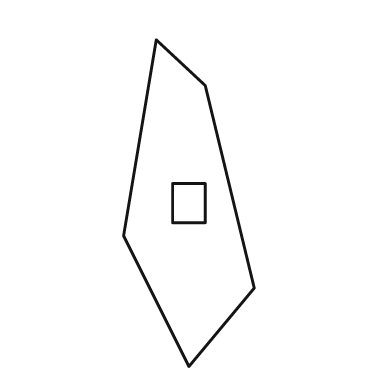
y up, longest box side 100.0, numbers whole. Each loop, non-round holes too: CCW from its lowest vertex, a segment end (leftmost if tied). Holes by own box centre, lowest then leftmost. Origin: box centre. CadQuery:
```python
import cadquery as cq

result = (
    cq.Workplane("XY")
    .moveTo(0.0, -50.0)
    .lineTo(20.0, -26.0)
    .lineTo(5.0, 36.0)
    .lineTo(-10.0, 50.0)
    .lineTo(-20.0, -10.0)
    .close()
    .moveTo(-5.0, -6.0)
    .lineTo(5.0, -6.0)
    .lineTo(5.0, 6.0)
    .lineTo(-5.0, 6.0)
    .close()
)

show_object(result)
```